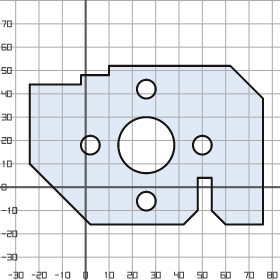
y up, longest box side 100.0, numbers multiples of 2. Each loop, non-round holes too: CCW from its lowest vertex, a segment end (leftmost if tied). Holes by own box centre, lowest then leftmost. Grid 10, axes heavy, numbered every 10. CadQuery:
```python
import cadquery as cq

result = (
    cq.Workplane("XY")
    .moveTo(2.0, -16.0)
    .lineTo(42.0, -16.0)
    .lineTo(48.0, -10.0)
    .lineTo(48.0, 4.0)
    .lineTo(54.0, 4.0)
    .lineTo(54.0, -10.0)
    .lineTo(60.0, -16.0)
    .lineTo(76.0, -16.0)
    .lineTo(76.0, 38.0)
    .lineTo(62.0, 52.0)
    .lineTo(10.0, 52.0)
    .lineTo(10.0, 48.0)
    .lineTo(-2.0, 48.0)
    .lineTo(-2.0, 44.0)
    .lineTo(-24.0, 44.0)
    .lineTo(-24.0, 10.0)
    .close()
    .moveTo(26.0, -6.0)
    .circle(4.0)
    .moveTo(2.0, 18.0)
    .circle(4.0)
    .moveTo(26.0, 18.0)
    .circle(12.0)
    .moveTo(50.0, 18.0)
    .circle(4.0)
    .moveTo(26.0, 42.0)
    .circle(4.0)
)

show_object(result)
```